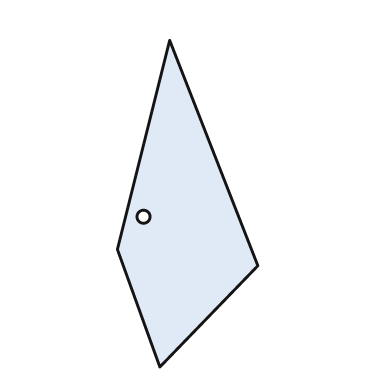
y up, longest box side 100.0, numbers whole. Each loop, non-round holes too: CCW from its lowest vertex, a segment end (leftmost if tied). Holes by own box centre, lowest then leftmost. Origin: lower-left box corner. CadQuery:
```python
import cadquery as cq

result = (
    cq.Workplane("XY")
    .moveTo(13.0, 0.0)
    .lineTo(43.0, 31.0)
    .lineTo(16.0, 100.0)
    .lineTo(0.0, 36.0)
    .close()
    .moveTo(8.0, 46.0)
    .circle(2.0)
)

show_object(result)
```